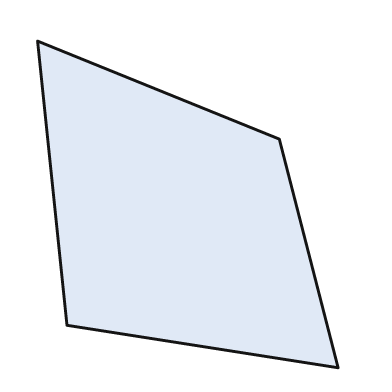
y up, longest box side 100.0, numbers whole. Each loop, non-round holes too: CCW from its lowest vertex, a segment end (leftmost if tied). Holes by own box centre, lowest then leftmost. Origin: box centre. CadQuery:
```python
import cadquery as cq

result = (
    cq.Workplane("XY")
    .moveTo(46.0, -50.0)
    .lineTo(28.0, 20.0)
    .lineTo(-46.0, 50.0)
    .lineTo(-37.0, -37.0)
    .close()
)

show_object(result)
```